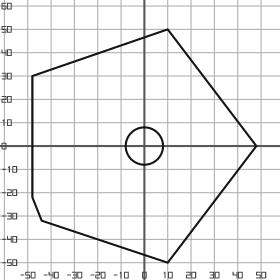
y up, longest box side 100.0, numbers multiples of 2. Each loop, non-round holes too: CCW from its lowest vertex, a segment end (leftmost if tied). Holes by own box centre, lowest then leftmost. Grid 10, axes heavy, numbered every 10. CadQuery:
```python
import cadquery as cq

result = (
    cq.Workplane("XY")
    .moveTo(10.0, -50.0)
    .lineTo(48.0, 0.0)
    .lineTo(10.0, 50.0)
    .lineTo(-48.0, 30.0)
    .lineTo(-48.0, -22.0)
    .lineTo(-44.0, -32.0)
    .close()
    .moveTo(0.0, 0.0)
    .circle(8.0)
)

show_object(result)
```